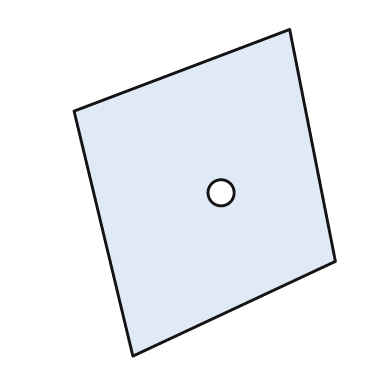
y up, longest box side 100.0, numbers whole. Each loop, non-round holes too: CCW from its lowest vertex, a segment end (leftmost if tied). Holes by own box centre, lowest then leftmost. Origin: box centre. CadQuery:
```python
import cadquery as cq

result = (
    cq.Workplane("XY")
    .moveTo(-22.0, -50.0)
    .lineTo(40.0, -21.0)
    .lineTo(26.0, 50.0)
    .lineTo(-40.0, 25.0)
    .close()
    .moveTo(5.0, 0.0)
    .circle(4.0)
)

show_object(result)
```